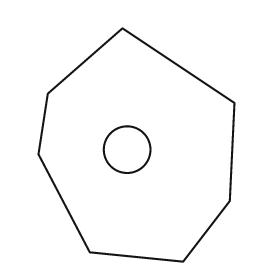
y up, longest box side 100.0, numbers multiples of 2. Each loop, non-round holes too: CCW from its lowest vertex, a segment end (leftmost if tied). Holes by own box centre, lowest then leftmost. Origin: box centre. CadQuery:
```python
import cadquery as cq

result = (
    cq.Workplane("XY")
    .moveTo(20.0, -50.0)
    .lineTo(40.0, -24.0)
    .lineTo(42.0, 18.0)
    .lineTo(-6.0, 50.0)
    .lineTo(-38.0, 22.0)
    .lineTo(-42.0, -4.0)
    .lineTo(-20.0, -46.0)
    .close()
    .moveTo(-4.0, -2.0)
    .circle(10.0)
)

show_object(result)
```